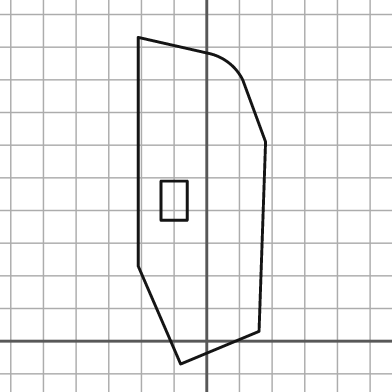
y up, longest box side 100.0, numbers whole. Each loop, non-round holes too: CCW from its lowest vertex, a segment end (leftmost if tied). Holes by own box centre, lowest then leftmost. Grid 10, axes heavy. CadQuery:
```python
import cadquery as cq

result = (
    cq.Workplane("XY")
    .moveTo(-8.0, -7.0)
    .lineTo(16.0, 3.0)
    .lineTo(18.0, 61.0)
    .lineTo(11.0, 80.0)
    .threePointArc((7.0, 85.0), (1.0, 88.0))
    .lineTo(-21.0, 93.0)
    .lineTo(-21.0, 23.0)
    .close()
    .moveTo(-14.0, 37.0)
    .lineTo(-6.0, 37.0)
    .lineTo(-6.0, 49.0)
    .lineTo(-14.0, 49.0)
    .close()
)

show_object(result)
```